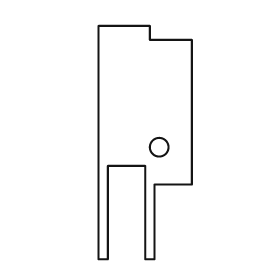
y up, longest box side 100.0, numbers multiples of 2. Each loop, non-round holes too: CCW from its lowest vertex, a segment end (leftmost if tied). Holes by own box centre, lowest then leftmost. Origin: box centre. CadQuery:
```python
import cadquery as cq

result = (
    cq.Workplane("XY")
    .moveTo(-20.0, -50.0)
    .lineTo(-16.0, -50.0)
    .lineTo(-16.0, -10.0)
    .lineTo(0.0, -10.0)
    .lineTo(0.0, -50.0)
    .lineTo(4.0, -50.0)
    .lineTo(4.0, -18.0)
    .lineTo(20.0, -18.0)
    .lineTo(20.0, 44.0)
    .lineTo(2.0, 44.0)
    .lineTo(2.0, 50.0)
    .lineTo(-20.0, 50.0)
    .close()
    .moveTo(6.0, -2.0)
    .circle(4.0)
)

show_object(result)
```